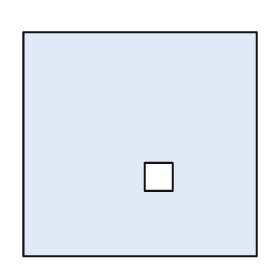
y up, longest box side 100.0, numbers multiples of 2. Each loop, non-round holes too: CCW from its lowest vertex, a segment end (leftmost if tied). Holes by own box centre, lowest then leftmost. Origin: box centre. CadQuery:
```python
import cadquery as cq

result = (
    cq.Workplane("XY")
    .moveTo(-50.0, -48.0)
    .lineTo(50.0, -48.0)
    .lineTo(50.0, 48.0)
    .lineTo(-50.0, 48.0)
    .close()
    .moveTo(2.0, -20.0)
    .lineTo(14.0, -20.0)
    .lineTo(14.0, -8.0)
    .lineTo(2.0, -8.0)
    .close()
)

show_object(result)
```